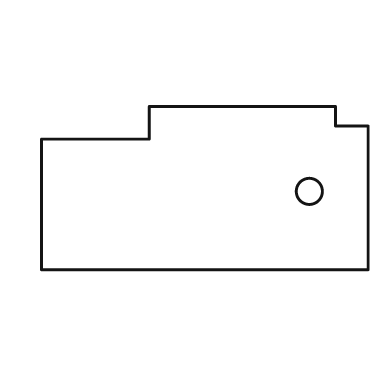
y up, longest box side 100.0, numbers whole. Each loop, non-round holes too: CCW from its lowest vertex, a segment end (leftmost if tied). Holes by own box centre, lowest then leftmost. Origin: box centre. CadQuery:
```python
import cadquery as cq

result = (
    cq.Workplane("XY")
    .moveTo(-50.0, -25.0)
    .lineTo(50.0, -25.0)
    .lineTo(50.0, 19.0)
    .lineTo(40.0, 19.0)
    .lineTo(40.0, 25.0)
    .lineTo(-17.0, 25.0)
    .lineTo(-17.0, 15.0)
    .lineTo(-50.0, 15.0)
    .close()
    .moveTo(32.0, -1.0)
    .circle(4.0)
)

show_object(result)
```